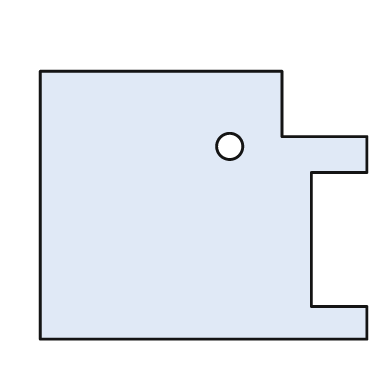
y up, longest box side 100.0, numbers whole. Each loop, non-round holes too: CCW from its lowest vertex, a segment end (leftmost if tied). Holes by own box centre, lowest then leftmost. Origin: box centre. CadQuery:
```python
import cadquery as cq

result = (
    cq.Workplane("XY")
    .moveTo(-50.0, -41.0)
    .lineTo(50.0, -41.0)
    .lineTo(50.0, -31.0)
    .lineTo(33.0, -31.0)
    .lineTo(33.0, 10.0)
    .lineTo(50.0, 10.0)
    .lineTo(50.0, 21.0)
    .lineTo(24.0, 21.0)
    .lineTo(24.0, 41.0)
    .lineTo(-50.0, 41.0)
    .close()
    .moveTo(8.0, 18.0)
    .circle(4.0)
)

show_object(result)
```